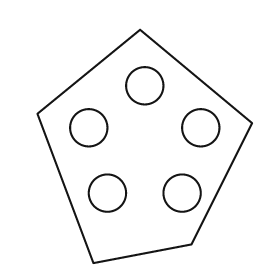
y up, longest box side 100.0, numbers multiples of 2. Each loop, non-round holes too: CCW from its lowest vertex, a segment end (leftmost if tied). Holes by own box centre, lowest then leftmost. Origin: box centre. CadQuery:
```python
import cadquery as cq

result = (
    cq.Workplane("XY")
    .moveTo(-22.0, -50.0)
    .lineTo(20.0, -42.0)
    .lineTo(46.0, 10.0)
    .lineTo(-2.0, 50.0)
    .lineTo(-46.0, 14.0)
    .close()
    .moveTo(-16.0, -20.0)
    .circle(8.0)
    .moveTo(16.0, -20.0)
    .circle(8.0)
    .moveTo(-24.0, 8.0)
    .circle(8.0)
    .moveTo(24.0, 8.0)
    .circle(8.0)
    .moveTo(0.0, 26.0)
    .circle(8.0)
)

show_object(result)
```